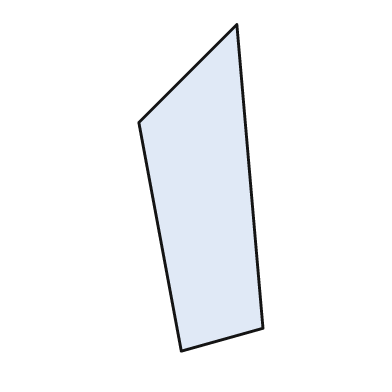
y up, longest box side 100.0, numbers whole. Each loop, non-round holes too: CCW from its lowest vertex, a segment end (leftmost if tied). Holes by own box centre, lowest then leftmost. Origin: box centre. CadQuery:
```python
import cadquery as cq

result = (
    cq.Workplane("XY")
    .moveTo(-6.0, -50.0)
    .lineTo(19.0, -43.0)
    .lineTo(11.0, 50.0)
    .lineTo(-19.0, 20.0)
    .close()
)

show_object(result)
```